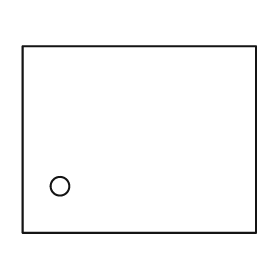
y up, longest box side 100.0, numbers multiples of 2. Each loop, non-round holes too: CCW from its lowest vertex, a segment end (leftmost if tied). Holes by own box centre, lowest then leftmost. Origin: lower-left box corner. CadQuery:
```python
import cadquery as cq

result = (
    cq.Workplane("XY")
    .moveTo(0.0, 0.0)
    .lineTo(100.0, 0.0)
    .lineTo(100.0, 80.0)
    .lineTo(0.0, 80.0)
    .close()
    .moveTo(16.0, 20.0)
    .circle(4.0)
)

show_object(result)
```